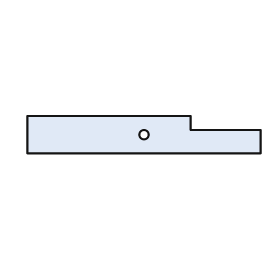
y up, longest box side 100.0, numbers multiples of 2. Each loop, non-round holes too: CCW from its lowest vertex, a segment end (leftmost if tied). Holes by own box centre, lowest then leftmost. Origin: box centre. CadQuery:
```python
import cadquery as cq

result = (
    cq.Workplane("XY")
    .moveTo(-50.0, -8.0)
    .lineTo(50.0, -8.0)
    .lineTo(50.0, 2.0)
    .lineTo(20.0, 2.0)
    .lineTo(20.0, 8.0)
    .lineTo(-50.0, 8.0)
    .close()
    .moveTo(0.0, 0.0)
    .circle(2.0)
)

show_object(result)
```